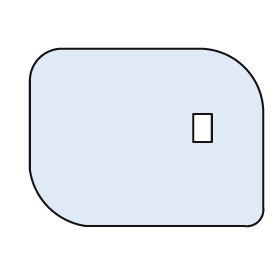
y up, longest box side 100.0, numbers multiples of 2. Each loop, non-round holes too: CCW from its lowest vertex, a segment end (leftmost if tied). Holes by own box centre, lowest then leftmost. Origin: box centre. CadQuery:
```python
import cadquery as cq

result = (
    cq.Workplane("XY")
    .moveTo(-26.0, -38.0)
    .lineTo(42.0, -38.0)
    .threePointArc((48.0, -36.0), (50.0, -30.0))
    .lineTo(50.0, 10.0)
    .threePointArc((42.0, 30.0), (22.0, 38.0))
    .lineTo(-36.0, 38.0)
    .threePointArc((-46.0, 34.0), (-50.0, 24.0))
    .lineTo(-50.0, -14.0)
    .threePointArc((-42.0, -30.0), (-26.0, -38.0))
    .close()
    .moveTo(20.0, -2.0)
    .lineTo(28.0, -2.0)
    .lineTo(28.0, 10.0)
    .lineTo(20.0, 10.0)
    .close()
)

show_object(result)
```